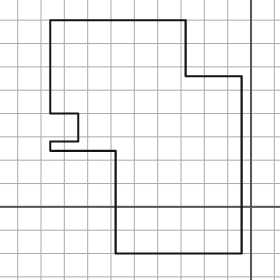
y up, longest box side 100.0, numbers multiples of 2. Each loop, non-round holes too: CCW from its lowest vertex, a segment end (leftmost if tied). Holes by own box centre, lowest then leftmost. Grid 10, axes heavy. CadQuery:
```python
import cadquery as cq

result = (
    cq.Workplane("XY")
    .moveTo(-58.0, -20.0)
    .lineTo(-4.0, -20.0)
    .lineTo(-4.0, 56.0)
    .lineTo(-28.0, 56.0)
    .lineTo(-28.0, 80.0)
    .lineTo(-86.0, 80.0)
    .lineTo(-86.0, 40.0)
    .lineTo(-74.0, 40.0)
    .lineTo(-74.0, 28.0)
    .lineTo(-86.0, 28.0)
    .lineTo(-86.0, 24.0)
    .lineTo(-58.0, 24.0)
    .close()
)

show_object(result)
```